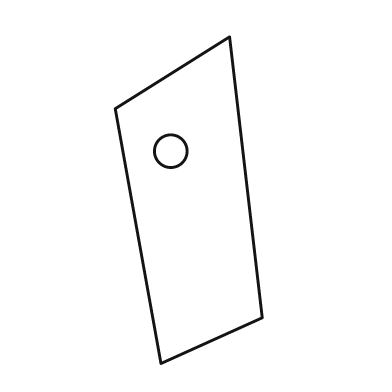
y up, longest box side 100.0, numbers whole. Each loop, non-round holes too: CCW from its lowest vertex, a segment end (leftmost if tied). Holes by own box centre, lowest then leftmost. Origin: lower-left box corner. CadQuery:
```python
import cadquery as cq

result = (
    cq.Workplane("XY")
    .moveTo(14.0, 0.0)
    .lineTo(45.0, 14.0)
    .lineTo(35.0, 100.0)
    .lineTo(0.0, 78.0)
    .close()
    .moveTo(17.0, 65.0)
    .circle(5.0)
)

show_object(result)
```